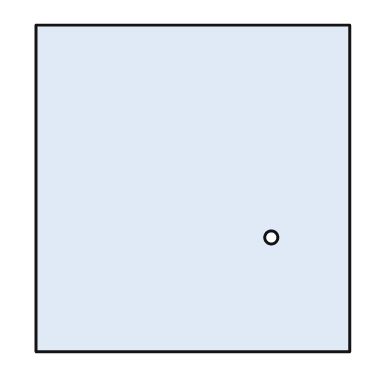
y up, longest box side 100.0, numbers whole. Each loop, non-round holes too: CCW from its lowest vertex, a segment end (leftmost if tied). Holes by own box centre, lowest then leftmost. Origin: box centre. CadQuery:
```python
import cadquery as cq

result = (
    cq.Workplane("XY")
    .moveTo(-48.0, -50.0)
    .lineTo(48.0, -50.0)
    .lineTo(48.0, 50.0)
    .lineTo(-48.0, 50.0)
    .close()
    .moveTo(24.0, -15.0)
    .circle(2.0)
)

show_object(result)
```